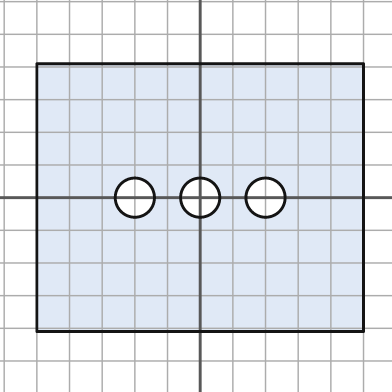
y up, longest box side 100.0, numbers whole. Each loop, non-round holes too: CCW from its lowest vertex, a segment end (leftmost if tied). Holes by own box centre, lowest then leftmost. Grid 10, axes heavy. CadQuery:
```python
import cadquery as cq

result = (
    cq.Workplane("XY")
    .moveTo(-50.0, -41.0)
    .lineTo(50.0, -41.0)
    .lineTo(50.0, 41.0)
    .lineTo(-50.0, 41.0)
    .close()
    .moveTo(-20.0, 0.0)
    .circle(6.0)
    .moveTo(0.0, 0.0)
    .circle(6.0)
    .moveTo(20.0, 0.0)
    .circle(6.0)
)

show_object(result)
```